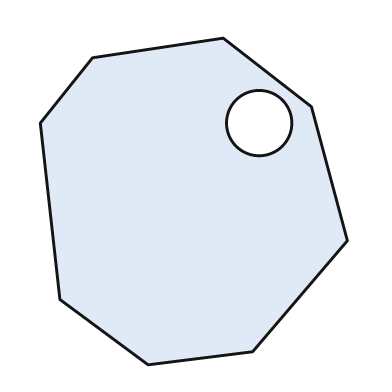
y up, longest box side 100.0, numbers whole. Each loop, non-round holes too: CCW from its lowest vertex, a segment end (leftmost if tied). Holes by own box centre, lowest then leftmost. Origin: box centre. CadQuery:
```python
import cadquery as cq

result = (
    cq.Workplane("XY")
    .moveTo(-14.0, -50.0)
    .lineTo(18.0, -46.0)
    .lineTo(47.0, -12.0)
    .lineTo(36.0, 29.0)
    .lineTo(9.0, 50.0)
    .lineTo(-31.0, 44.0)
    .lineTo(-47.0, 24.0)
    .lineTo(-41.0, -30.0)
    .close()
    .moveTo(20.0, 24.0)
    .circle(10.0)
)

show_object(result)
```